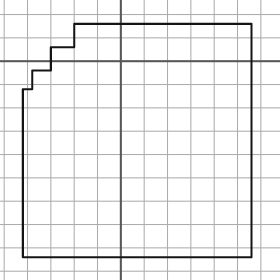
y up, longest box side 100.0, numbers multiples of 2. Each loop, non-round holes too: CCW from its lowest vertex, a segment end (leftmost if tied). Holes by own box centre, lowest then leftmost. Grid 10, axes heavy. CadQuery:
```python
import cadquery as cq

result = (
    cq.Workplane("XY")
    .moveTo(-42.0, -84.0)
    .lineTo(56.0, -84.0)
    .lineTo(56.0, 16.0)
    .lineTo(-20.0, 16.0)
    .lineTo(-20.0, 6.0)
    .lineTo(-30.0, 6.0)
    .lineTo(-30.0, -4.0)
    .lineTo(-38.0, -4.0)
    .lineTo(-38.0, -12.0)
    .lineTo(-42.0, -12.0)
    .close()
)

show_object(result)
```